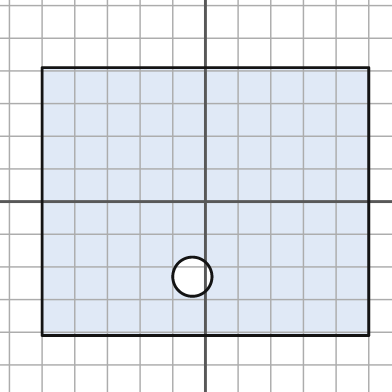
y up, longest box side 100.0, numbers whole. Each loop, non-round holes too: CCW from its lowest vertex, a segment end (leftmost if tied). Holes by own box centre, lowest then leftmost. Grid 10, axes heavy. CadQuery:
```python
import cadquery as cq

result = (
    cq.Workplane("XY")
    .moveTo(-50.0, -41.0)
    .lineTo(50.0, -41.0)
    .lineTo(50.0, 41.0)
    .lineTo(-50.0, 41.0)
    .close()
    .moveTo(-4.0, -23.0)
    .circle(6.0)
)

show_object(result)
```